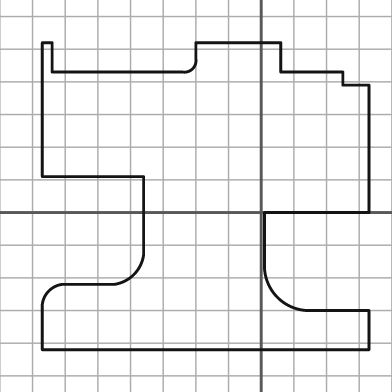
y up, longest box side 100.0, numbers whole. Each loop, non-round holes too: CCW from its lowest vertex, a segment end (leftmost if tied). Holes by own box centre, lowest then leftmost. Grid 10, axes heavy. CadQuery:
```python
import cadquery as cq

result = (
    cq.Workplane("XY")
    .moveTo(-67.0, -42.0)
    .lineTo(33.0, -42.0)
    .lineTo(33.0, -30.0)
    .lineTo(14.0, -30.0)
    .threePointArc((5.0, -26.0), (1.0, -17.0))
    .lineTo(1.0, 0.0)
    .lineTo(33.0, 0.0)
    .lineTo(33.0, 39.0)
    .lineTo(25.0, 39.0)
    .lineTo(25.0, 43.0)
    .lineTo(6.0, 43.0)
    .lineTo(6.0, 52.0)
    .lineTo(-20.0, 52.0)
    .lineTo(-20.0, 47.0)
    .threePointArc((-21.0, 44.0), (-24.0, 43.0))
    .lineTo(-64.0, 43.0)
    .lineTo(-64.0, 52.0)
    .lineTo(-67.0, 52.0)
    .lineTo(-67.0, 11.0)
    .lineTo(-36.0, 11.0)
    .lineTo(-36.0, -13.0)
    .threePointArc((-39.0, -19.0), (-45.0, -22.0))
    .lineTo(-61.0, -22.0)
    .threePointArc((-65.0, -24.0), (-67.0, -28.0))
    .close()
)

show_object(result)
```